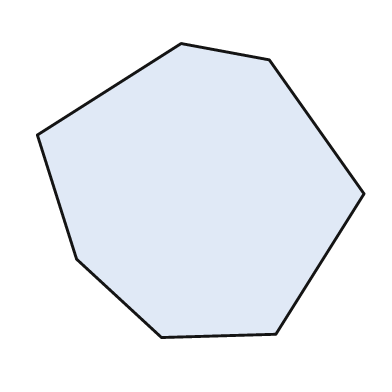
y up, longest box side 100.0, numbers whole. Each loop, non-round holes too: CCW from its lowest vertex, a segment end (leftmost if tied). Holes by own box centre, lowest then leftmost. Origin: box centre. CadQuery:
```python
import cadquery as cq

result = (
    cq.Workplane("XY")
    .moveTo(-12.0, -45.0)
    .lineTo(23.0, -44.0)
    .lineTo(50.0, -1.0)
    .lineTo(21.0, 40.0)
    .lineTo(-6.0, 45.0)
    .lineTo(-50.0, 17.0)
    .lineTo(-38.0, -21.0)
    .close()
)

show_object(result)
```